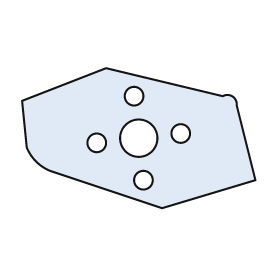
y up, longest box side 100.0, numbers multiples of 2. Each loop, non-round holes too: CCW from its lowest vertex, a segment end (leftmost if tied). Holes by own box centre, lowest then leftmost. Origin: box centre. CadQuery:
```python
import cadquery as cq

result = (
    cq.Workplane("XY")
    .moveTo(10.0, -30.0)
    .lineTo(50.0, -18.0)
    .lineTo(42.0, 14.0)
    .threePointArc((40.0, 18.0), (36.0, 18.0))
    .lineTo(-14.0, 30.0)
    .lineTo(-50.0, 16.0)
    .lineTo(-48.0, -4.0)
    .threePointArc((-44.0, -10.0), (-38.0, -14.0))
    .close()
    .moveTo(2.0, -18.0)
    .circle(4.0)
    .moveTo(-18.0, -2.0)
    .circle(4.0)
    .moveTo(0.0, 0.0)
    .circle(8.0)
    .moveTo(18.0, 2.0)
    .circle(4.0)
    .moveTo(-2.0, 18.0)
    .circle(4.0)
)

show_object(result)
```